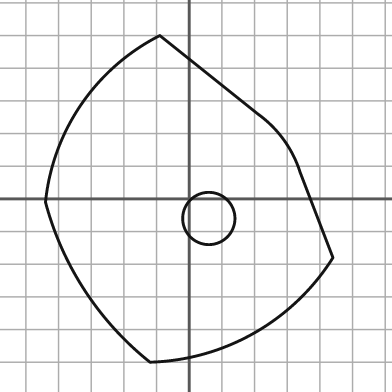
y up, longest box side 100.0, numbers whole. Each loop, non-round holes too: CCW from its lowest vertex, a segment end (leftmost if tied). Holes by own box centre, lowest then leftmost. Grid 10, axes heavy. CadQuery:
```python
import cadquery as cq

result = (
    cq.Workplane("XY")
    .moveTo(-12.0, -50.0)
    .threePointArc((20.0, -41.0), (44.0, -18.0))
    .lineTo(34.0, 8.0)
    .threePointArc((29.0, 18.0), (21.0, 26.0))
    .lineTo(-9.0, 50.0)
    .threePointArc((-33.0, 29.0), (-44.0, -1.0))
    .threePointArc((-32.0, -28.0), (-12.0, -50.0))
    .close()
    .moveTo(6.0, -6.0)
    .circle(8.0)
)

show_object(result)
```